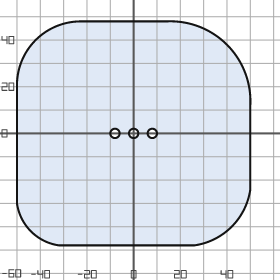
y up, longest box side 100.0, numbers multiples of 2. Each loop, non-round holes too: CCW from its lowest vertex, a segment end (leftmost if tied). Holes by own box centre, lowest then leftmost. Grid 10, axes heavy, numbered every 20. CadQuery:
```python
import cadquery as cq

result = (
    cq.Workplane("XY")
    .moveTo(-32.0, -48.0)
    .lineTo(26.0, -48.0)
    .threePointArc((42.0, -40.0), (50.0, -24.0))
    .lineTo(50.0, 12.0)
    .threePointArc((40.0, 38.0), (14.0, 48.0))
    .lineTo(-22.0, 48.0)
    .threePointArc((-42.0, 40.0), (-50.0, 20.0))
    .lineTo(-50.0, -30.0)
    .threePointArc((-44.0, -42.0), (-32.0, -48.0))
    .close()
    .moveTo(-8.0, 0.0)
    .circle(2.0)
    .moveTo(0.0, 0.0)
    .circle(2.0)
    .moveTo(8.0, 0.0)
    .circle(2.0)
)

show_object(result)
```